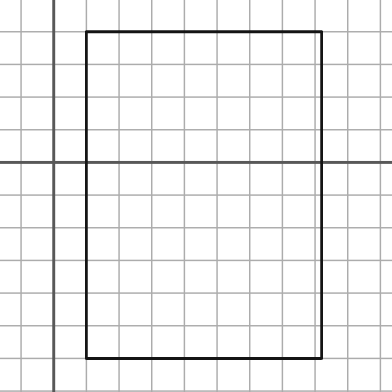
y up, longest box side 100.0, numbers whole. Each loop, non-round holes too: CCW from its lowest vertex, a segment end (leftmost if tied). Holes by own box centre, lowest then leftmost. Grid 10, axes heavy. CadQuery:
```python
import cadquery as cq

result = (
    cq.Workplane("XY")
    .moveTo(10.0, -60.0)
    .lineTo(82.0, -60.0)
    .lineTo(82.0, 40.0)
    .lineTo(10.0, 40.0)
    .close()
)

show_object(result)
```